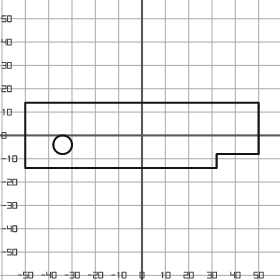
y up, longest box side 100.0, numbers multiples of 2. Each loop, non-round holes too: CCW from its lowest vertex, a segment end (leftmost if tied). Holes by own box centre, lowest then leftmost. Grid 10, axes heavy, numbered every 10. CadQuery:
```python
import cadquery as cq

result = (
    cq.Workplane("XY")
    .moveTo(-50.0, -14.0)
    .lineTo(32.0, -14.0)
    .lineTo(32.0, -8.0)
    .lineTo(50.0, -8.0)
    .lineTo(50.0, 14.0)
    .lineTo(-50.0, 14.0)
    .close()
    .moveTo(-34.0, -4.0)
    .circle(4.0)
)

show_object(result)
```